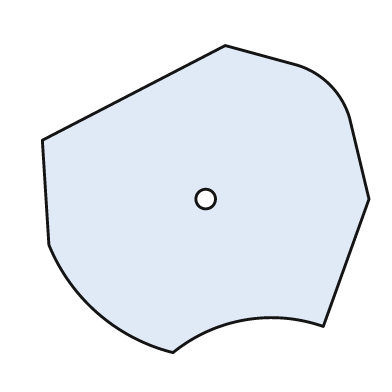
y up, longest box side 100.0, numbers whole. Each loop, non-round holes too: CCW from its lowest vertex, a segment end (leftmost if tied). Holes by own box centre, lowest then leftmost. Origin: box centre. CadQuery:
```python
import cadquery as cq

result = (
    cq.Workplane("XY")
    .moveTo(-10.0, -47.0)
    .threePointArc((12.0, -37.0), (36.0, -39.0))
    .lineTo(50.0, 0.0)
    .lineTo(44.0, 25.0)
    .threePointArc((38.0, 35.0), (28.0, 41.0))
    .lineTo(6.0, 47.0)
    .lineTo(-50.0, 18.0)
    .lineTo(-48.0, -14.0)
    .threePointArc((-33.0, -35.0), (-10.0, -47.0))
    .close()
    .moveTo(0.0, 0.0)
    .circle(3.0)
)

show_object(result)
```